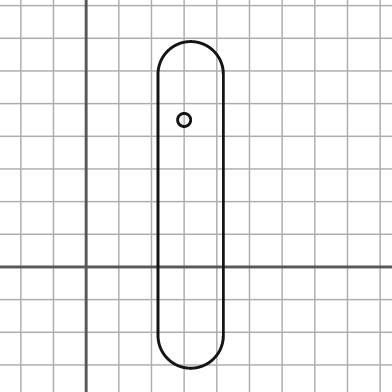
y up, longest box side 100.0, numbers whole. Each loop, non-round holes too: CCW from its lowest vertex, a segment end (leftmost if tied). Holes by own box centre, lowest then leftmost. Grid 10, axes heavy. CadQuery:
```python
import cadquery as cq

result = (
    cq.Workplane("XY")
    .moveTo(22.0, -21.0)
    .threePointArc((32.0, -31.0), (42.0, -21.0))
    .lineTo(42.0, 59.0)
    .threePointArc((32.0, 69.0), (22.0, 59.0))
    .close()
    .moveTo(30.0, 45.0)
    .circle(2.0)
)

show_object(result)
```